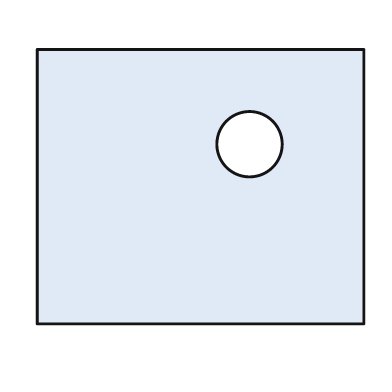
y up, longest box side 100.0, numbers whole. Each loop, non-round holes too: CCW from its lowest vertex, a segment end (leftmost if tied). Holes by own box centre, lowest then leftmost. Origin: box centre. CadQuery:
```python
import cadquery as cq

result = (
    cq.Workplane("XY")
    .moveTo(-50.0, -42.0)
    .lineTo(50.0, -42.0)
    .lineTo(50.0, 42.0)
    .lineTo(-50.0, 42.0)
    .close()
    .moveTo(15.0, 13.0)
    .circle(10.0)
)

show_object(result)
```